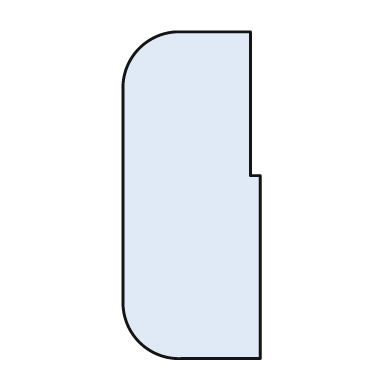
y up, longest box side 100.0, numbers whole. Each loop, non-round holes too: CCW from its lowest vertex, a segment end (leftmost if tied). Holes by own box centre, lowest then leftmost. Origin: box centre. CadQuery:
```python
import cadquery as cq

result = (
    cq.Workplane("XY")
    .moveTo(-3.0, -50.0)
    .lineTo(21.0, -50.0)
    .lineTo(21.0, 6.0)
    .lineTo(18.0, 6.0)
    .lineTo(18.0, 50.0)
    .lineTo(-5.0, 50.0)
    .threePointArc((-16.0, 45.0), (-21.0, 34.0))
    .lineTo(-21.0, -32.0)
    .threePointArc((-16.0, -45.0), (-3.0, -50.0))
    .close()
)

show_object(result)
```